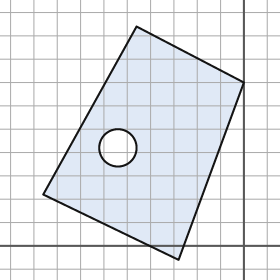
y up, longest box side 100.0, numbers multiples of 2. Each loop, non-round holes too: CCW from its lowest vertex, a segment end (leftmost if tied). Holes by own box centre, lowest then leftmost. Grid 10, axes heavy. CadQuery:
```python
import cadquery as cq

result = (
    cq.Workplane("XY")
    .moveTo(-28.0, -6.0)
    .lineTo(0.0, 70.0)
    .lineTo(-46.0, 94.0)
    .lineTo(-86.0, 22.0)
    .close()
    .moveTo(-54.0, 42.0)
    .circle(8.0)
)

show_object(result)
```